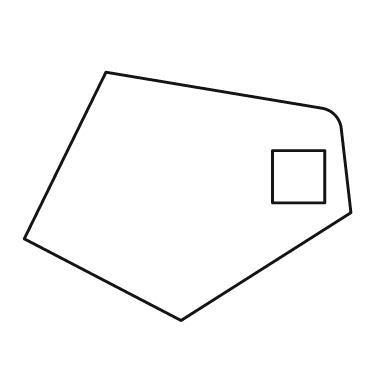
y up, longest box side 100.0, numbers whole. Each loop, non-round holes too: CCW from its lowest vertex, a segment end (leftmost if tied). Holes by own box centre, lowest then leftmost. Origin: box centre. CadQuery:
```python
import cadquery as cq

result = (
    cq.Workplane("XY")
    .moveTo(-2.0, -38.0)
    .lineTo(50.0, -5.0)
    .lineTo(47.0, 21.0)
    .threePointArc((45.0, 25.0), (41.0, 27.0))
    .lineTo(-25.0, 38.0)
    .lineTo(-50.0, -13.0)
    .close()
    .moveTo(26.0, -2.0)
    .lineTo(42.0, -2.0)
    .lineTo(42.0, 14.0)
    .lineTo(26.0, 14.0)
    .close()
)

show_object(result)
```